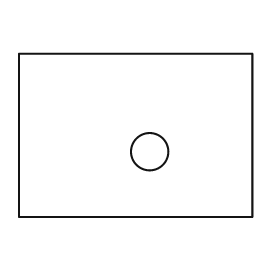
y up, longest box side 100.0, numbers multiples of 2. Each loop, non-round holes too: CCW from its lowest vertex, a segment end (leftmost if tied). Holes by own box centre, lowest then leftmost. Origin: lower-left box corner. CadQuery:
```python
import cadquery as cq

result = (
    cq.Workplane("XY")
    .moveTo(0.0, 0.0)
    .lineTo(100.0, 0.0)
    .lineTo(100.0, 70.0)
    .lineTo(0.0, 70.0)
    .close()
    .moveTo(56.0, 28.0)
    .circle(8.0)
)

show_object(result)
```